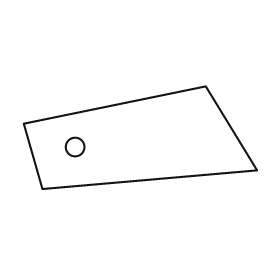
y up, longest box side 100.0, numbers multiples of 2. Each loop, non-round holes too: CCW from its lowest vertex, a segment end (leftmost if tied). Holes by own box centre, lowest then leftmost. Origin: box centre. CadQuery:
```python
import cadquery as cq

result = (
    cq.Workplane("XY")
    .moveTo(-42.0, -22.0)
    .lineTo(50.0, -14.0)
    .lineTo(28.0, 22.0)
    .lineTo(-50.0, 6.0)
    .close()
    .moveTo(-28.0, -4.0)
    .circle(4.0)
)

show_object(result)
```